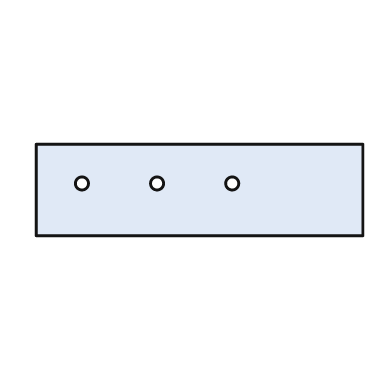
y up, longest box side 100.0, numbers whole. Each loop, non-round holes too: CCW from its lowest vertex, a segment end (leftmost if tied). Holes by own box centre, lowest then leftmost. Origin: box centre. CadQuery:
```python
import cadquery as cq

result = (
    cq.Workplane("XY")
    .moveTo(-50.0, -14.0)
    .lineTo(50.0, -14.0)
    .lineTo(50.0, 14.0)
    .lineTo(-50.0, 14.0)
    .close()
    .moveTo(-36.0, 2.0)
    .circle(2.0)
    .moveTo(-13.0, 2.0)
    .circle(2.0)
    .moveTo(10.0, 2.0)
    .circle(2.0)
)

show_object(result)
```